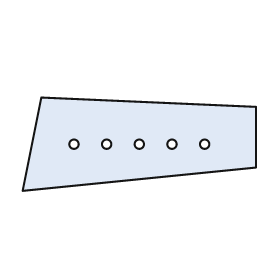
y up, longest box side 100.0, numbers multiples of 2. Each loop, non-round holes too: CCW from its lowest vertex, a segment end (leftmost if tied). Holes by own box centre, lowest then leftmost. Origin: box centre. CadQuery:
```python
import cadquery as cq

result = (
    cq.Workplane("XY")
    .moveTo(-50.0, -20.0)
    .lineTo(50.0, -10.0)
    .lineTo(50.0, 16.0)
    .lineTo(-42.0, 20.0)
    .close()
    .moveTo(-28.0, 0.0)
    .circle(2.0)
    .moveTo(-14.0, 0.0)
    .circle(2.0)
    .moveTo(0.0, 0.0)
    .circle(2.0)
    .moveTo(14.0, 0.0)
    .circle(2.0)
    .moveTo(28.0, 0.0)
    .circle(2.0)
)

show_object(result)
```